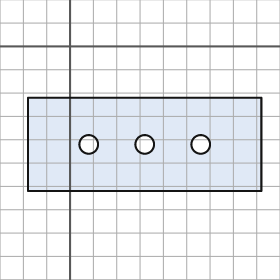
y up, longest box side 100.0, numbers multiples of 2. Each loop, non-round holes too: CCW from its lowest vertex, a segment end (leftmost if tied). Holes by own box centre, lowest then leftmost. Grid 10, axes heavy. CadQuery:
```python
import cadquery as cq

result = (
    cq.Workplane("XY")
    .moveTo(-18.0, -62.0)
    .lineTo(82.0, -62.0)
    .lineTo(82.0, -22.0)
    .lineTo(-18.0, -22.0)
    .close()
    .moveTo(8.0, -42.0)
    .circle(4.0)
    .moveTo(32.0, -42.0)
    .circle(4.0)
    .moveTo(56.0, -42.0)
    .circle(4.0)
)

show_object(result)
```